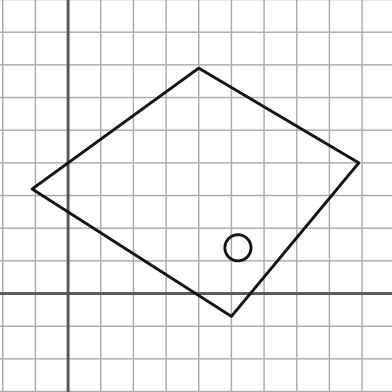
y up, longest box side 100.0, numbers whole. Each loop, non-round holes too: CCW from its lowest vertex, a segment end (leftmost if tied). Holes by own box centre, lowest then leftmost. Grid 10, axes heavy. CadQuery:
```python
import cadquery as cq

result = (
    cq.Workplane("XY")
    .moveTo(50.0, -7.0)
    .lineTo(89.0, 40.0)
    .lineTo(40.0, 69.0)
    .lineTo(-11.0, 32.0)
    .close()
    .moveTo(52.0, 14.0)
    .circle(4.0)
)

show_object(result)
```